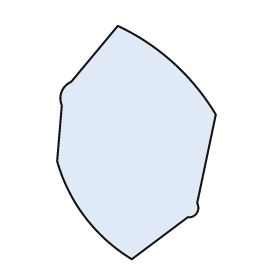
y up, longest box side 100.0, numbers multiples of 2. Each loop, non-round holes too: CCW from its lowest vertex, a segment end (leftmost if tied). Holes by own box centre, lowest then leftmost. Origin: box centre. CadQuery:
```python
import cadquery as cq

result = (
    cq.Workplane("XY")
    .moveTo(-2.0, -50.0)
    .lineTo(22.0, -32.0)
    .threePointArc((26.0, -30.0), (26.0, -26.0))
    .lineTo(34.0, 12.0)
    .threePointArc((16.0, 34.0), (-8.0, 50.0))
    .lineTo(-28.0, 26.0)
    .threePointArc((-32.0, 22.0), (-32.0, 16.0))
    .lineTo(-34.0, -8.0)
    .threePointArc((-22.0, -32.0), (-2.0, -50.0))
    .close()
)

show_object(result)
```